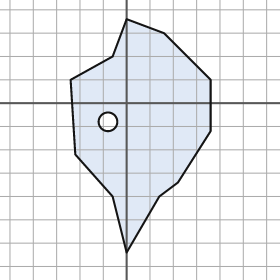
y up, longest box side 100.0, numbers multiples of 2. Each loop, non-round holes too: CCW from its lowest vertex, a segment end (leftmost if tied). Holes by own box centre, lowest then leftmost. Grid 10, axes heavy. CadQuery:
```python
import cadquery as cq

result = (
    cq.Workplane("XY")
    .moveTo(0.0, -64.0)
    .lineTo(14.0, -40.0)
    .lineTo(22.0, -34.0)
    .lineTo(36.0, -12.0)
    .lineTo(36.0, 10.0)
    .lineTo(16.0, 30.0)
    .lineTo(0.0, 36.0)
    .lineTo(-6.0, 20.0)
    .lineTo(-24.0, 10.0)
    .lineTo(-22.0, -22.0)
    .lineTo(-6.0, -40.0)
    .close()
    .moveTo(-8.0, -8.0)
    .circle(4.0)
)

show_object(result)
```